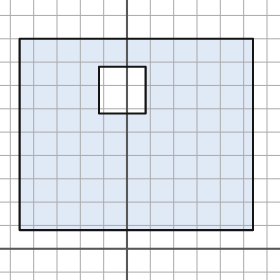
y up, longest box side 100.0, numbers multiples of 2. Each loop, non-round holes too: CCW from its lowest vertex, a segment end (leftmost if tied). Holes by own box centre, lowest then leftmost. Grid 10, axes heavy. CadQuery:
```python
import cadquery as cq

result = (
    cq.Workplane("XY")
    .moveTo(-46.0, 8.0)
    .lineTo(54.0, 8.0)
    .lineTo(54.0, 90.0)
    .lineTo(-46.0, 90.0)
    .close()
    .moveTo(-12.0, 58.0)
    .lineTo(8.0, 58.0)
    .lineTo(8.0, 78.0)
    .lineTo(-12.0, 78.0)
    .close()
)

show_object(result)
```